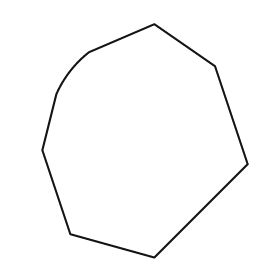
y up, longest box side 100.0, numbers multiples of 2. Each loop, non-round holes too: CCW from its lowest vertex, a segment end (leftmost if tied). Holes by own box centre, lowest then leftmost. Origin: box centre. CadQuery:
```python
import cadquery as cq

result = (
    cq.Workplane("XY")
    .moveTo(4.0, -50.0)
    .lineTo(44.0, -10.0)
    .lineTo(30.0, 32.0)
    .lineTo(4.0, 50.0)
    .lineTo(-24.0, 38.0)
    .threePointArc((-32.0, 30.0), (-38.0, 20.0))
    .lineTo(-44.0, -4.0)
    .lineTo(-32.0, -40.0)
    .close()
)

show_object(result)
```